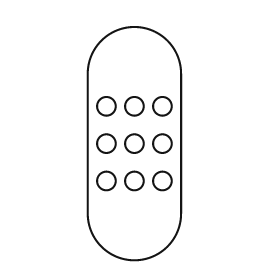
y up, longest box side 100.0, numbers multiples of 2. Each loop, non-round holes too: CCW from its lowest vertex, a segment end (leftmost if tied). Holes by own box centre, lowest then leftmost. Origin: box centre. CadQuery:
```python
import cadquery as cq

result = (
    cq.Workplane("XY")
    .moveTo(-20.0, -30.0)
    .threePointArc((0.0, -50.0), (20.0, -30.0))
    .lineTo(20.0, 30.0)
    .threePointArc((0.0, 50.0), (-20.0, 30.0))
    .close()
    .moveTo(-12.0, -16.0)
    .circle(4.0)
    .moveTo(0.0, -16.0)
    .circle(4.0)
    .moveTo(12.0, -16.0)
    .circle(4.0)
    .moveTo(-12.0, 0.0)
    .circle(4.0)
    .moveTo(0.0, 0.0)
    .circle(4.0)
    .moveTo(12.0, 0.0)
    .circle(4.0)
    .moveTo(-12.0, 16.0)
    .circle(4.0)
    .moveTo(0.0, 16.0)
    .circle(4.0)
    .moveTo(12.0, 16.0)
    .circle(4.0)
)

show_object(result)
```